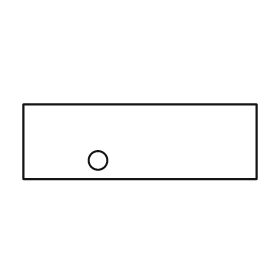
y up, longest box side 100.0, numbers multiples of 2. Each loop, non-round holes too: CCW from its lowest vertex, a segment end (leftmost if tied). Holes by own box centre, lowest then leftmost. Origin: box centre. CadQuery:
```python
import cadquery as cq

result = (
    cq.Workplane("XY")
    .moveTo(-50.0, -16.0)
    .lineTo(50.0, -16.0)
    .lineTo(50.0, 16.0)
    .lineTo(-50.0, 16.0)
    .close()
    .moveTo(-18.0, -8.0)
    .circle(4.0)
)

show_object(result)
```